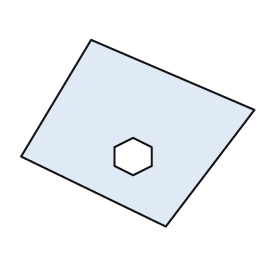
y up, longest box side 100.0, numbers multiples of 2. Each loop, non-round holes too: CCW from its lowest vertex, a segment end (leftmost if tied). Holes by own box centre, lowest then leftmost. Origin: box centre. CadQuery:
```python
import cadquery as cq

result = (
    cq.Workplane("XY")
    .moveTo(12.0, -40.0)
    .lineTo(50.0, 10.0)
    .lineTo(-20.0, 40.0)
    .lineTo(-50.0, -10.0)
    .close()
    .moveTo(-2.0, -18.0)
    .lineTo(6.0, -14.0)
    .lineTo(6.0, -6.0)
    .lineTo(-2.0, -2.0)
    .lineTo(-10.0, -6.0)
    .lineTo(-10.0, -14.0)
    .close()
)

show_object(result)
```